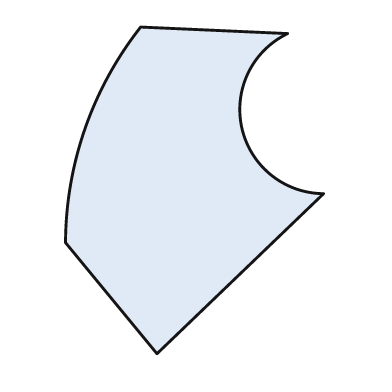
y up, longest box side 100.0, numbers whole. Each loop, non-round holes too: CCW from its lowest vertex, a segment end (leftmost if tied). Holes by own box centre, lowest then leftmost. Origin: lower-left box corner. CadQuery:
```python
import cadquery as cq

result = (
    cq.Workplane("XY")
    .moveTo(28.0, 0.0)
    .lineTo(79.0, 49.0)
    .threePointArc((54.0, 69.0), (68.0, 98.0))
    .lineTo(23.0, 100.0)
    .threePointArc((6.0, 69.0), (0.0, 34.0))
    .close()
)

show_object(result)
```